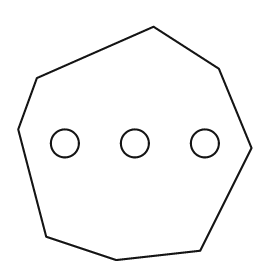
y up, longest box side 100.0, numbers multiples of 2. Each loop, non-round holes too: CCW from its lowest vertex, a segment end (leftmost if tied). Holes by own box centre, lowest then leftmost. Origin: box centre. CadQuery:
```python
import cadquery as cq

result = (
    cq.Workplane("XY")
    .moveTo(-8.0, -50.0)
    .lineTo(28.0, -46.0)
    .lineTo(50.0, -2.0)
    .lineTo(36.0, 32.0)
    .lineTo(8.0, 50.0)
    .lineTo(-42.0, 28.0)
    .lineTo(-50.0, 6.0)
    .lineTo(-38.0, -40.0)
    .close()
    .moveTo(-30.0, 0.0)
    .circle(6.0)
    .moveTo(0.0, 0.0)
    .circle(6.0)
    .moveTo(30.0, 0.0)
    .circle(6.0)
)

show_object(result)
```